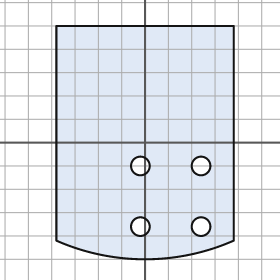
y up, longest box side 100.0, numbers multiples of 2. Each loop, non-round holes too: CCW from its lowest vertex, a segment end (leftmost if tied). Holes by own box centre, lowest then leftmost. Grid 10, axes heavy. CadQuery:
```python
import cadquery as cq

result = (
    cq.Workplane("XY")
    .moveTo(-38.0, -42.0)
    .threePointArc((0.0, -50.0), (38.0, -42.0))
    .lineTo(38.0, 50.0)
    .lineTo(-38.0, 50.0)
    .close()
    .moveTo(-2.0, -36.0)
    .circle(4.0)
    .moveTo(24.0, -36.0)
    .circle(4.0)
    .moveTo(-2.0, -10.0)
    .circle(4.0)
    .moveTo(24.0, -10.0)
    .circle(4.0)
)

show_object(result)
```